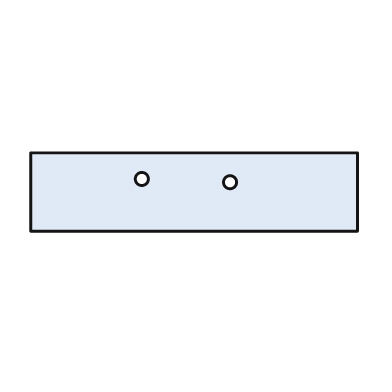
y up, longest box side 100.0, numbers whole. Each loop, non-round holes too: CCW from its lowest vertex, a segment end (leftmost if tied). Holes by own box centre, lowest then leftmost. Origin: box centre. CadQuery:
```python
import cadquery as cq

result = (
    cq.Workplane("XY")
    .moveTo(-50.0, -12.0)
    .lineTo(50.0, -12.0)
    .lineTo(50.0, 12.0)
    .lineTo(-50.0, 12.0)
    .close()
    .moveTo(11.0, 3.0)
    .circle(2.0)
    .moveTo(-16.0, 4.0)
    .circle(2.0)
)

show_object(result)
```